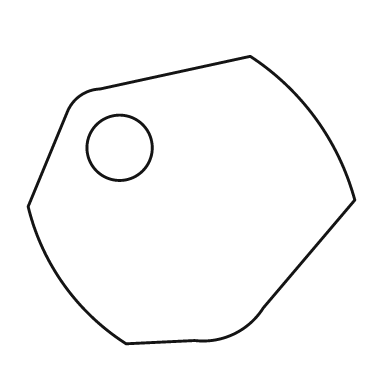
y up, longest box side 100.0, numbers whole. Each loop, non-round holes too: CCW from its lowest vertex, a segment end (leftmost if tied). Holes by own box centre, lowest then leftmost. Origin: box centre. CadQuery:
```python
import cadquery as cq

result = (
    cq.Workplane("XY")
    .moveTo(-20.0, -44.0)
    .lineTo(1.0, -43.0)
    .threePointArc((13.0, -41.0), (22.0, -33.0))
    .lineTo(50.0, 0.0)
    .threePointArc((38.0, 25.0), (18.0, 44.0))
    .lineTo(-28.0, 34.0)
    .threePointArc((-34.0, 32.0), (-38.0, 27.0))
    .lineTo(-50.0, -2.0)
    .threePointArc((-39.0, -26.0), (-20.0, -44.0))
    .close()
    .moveTo(-22.0, 16.0)
    .circle(10.0)
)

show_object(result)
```